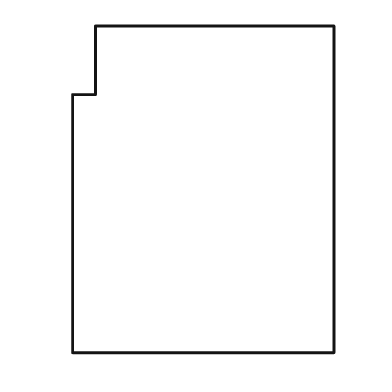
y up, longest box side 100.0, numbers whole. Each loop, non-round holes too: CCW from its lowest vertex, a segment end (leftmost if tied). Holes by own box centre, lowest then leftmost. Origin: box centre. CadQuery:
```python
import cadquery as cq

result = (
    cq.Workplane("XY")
    .moveTo(-40.0, -50.0)
    .lineTo(40.0, -50.0)
    .lineTo(40.0, 50.0)
    .lineTo(-33.0, 50.0)
    .lineTo(-33.0, 29.0)
    .lineTo(-40.0, 29.0)
    .close()
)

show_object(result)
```